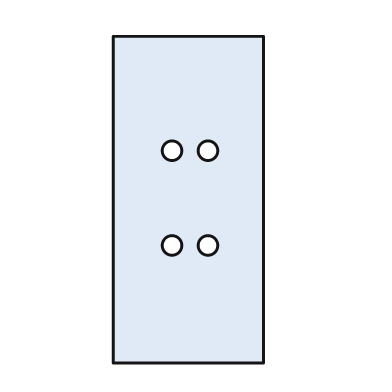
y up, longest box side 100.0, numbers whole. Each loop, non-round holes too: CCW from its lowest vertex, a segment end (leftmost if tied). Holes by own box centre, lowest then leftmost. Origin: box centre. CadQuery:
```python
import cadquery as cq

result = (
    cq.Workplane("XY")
    .moveTo(-23.0, -50.0)
    .lineTo(23.0, -50.0)
    .lineTo(23.0, 50.0)
    .lineTo(-23.0, 50.0)
    .close()
    .moveTo(-5.0, -14.0)
    .circle(3.0)
    .moveTo(6.0, -14.0)
    .circle(3.0)
    .moveTo(-5.0, 15.0)
    .circle(3.0)
    .moveTo(6.0, 15.0)
    .circle(3.0)
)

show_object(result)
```